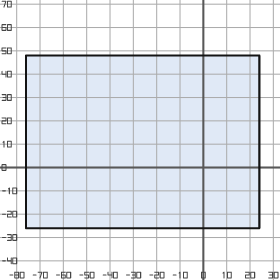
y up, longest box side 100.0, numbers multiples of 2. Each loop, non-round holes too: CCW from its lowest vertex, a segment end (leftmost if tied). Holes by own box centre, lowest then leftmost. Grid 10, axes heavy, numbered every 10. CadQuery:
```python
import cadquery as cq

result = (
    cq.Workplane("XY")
    .moveTo(-76.0, -26.0)
    .lineTo(24.0, -26.0)
    .lineTo(24.0, 48.0)
    .lineTo(-76.0, 48.0)
    .close()
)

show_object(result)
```